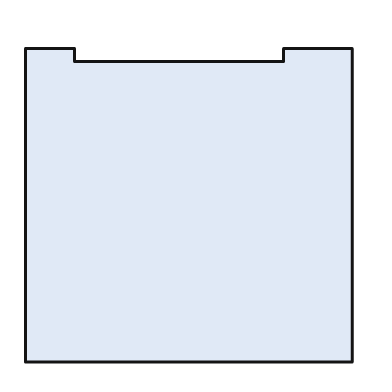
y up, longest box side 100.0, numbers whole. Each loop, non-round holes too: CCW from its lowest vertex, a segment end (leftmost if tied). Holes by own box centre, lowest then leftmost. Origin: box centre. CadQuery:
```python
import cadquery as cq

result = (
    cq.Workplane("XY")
    .moveTo(-50.0, -48.0)
    .lineTo(50.0, -48.0)
    .lineTo(50.0, 48.0)
    .lineTo(29.0, 48.0)
    .lineTo(29.0, 44.0)
    .lineTo(-35.0, 44.0)
    .lineTo(-35.0, 48.0)
    .lineTo(-50.0, 48.0)
    .close()
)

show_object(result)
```